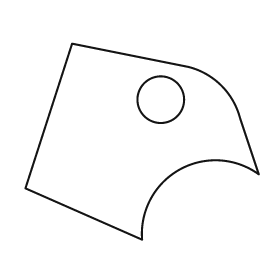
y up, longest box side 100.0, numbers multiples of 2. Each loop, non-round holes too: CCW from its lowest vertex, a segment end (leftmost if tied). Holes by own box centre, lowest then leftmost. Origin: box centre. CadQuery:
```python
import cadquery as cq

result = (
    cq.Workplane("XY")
    .moveTo(0.0, -42.0)
    .threePointArc((16.0, -12.0), (50.0, -14.0))
    .lineTo(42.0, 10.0)
    .threePointArc((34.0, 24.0), (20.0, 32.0))
    .lineTo(-30.0, 42.0)
    .lineTo(-50.0, -20.0)
    .close()
    .moveTo(8.0, 18.0)
    .circle(10.0)
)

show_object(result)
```